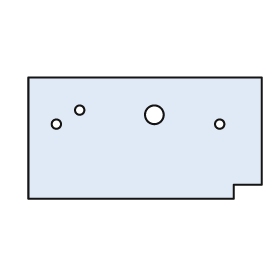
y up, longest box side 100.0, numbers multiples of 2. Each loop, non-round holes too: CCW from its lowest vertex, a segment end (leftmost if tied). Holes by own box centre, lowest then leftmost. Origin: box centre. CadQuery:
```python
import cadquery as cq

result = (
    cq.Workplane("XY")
    .moveTo(-50.0, -26.0)
    .lineTo(38.0, -26.0)
    .lineTo(38.0, -20.0)
    .lineTo(50.0, -20.0)
    .lineTo(50.0, 26.0)
    .lineTo(-50.0, 26.0)
    .close()
    .moveTo(-38.0, 6.0)
    .circle(2.0)
    .moveTo(32.0, 6.0)
    .circle(2.0)
    .moveTo(4.0, 10.0)
    .circle(4.0)
    .moveTo(-28.0, 12.0)
    .circle(2.0)
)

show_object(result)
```